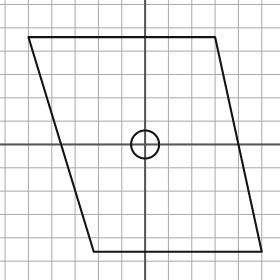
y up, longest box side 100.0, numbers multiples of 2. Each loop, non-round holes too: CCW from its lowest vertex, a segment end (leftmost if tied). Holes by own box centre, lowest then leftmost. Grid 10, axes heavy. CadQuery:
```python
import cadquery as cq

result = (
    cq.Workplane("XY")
    .moveTo(-22.0, -46.0)
    .lineTo(50.0, -46.0)
    .lineTo(30.0, 46.0)
    .lineTo(-50.0, 46.0)
    .close()
    .moveTo(0.0, 0.0)
    .circle(6.0)
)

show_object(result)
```